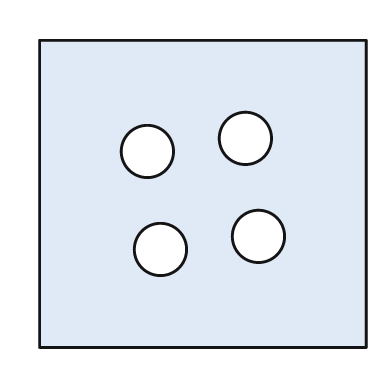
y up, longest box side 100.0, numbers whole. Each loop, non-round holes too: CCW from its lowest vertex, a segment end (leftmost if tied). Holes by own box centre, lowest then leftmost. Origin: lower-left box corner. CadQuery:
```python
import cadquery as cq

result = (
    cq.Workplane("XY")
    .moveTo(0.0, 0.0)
    .lineTo(100.0, 0.0)
    .lineTo(100.0, 94.0)
    .lineTo(0.0, 94.0)
    .close()
    .moveTo(37.0, 30.0)
    .circle(8.0)
    .moveTo(67.0, 34.0)
    .circle(8.0)
    .moveTo(33.0, 60.0)
    .circle(8.0)
    .moveTo(63.0, 64.0)
    .circle(8.0)
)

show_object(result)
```